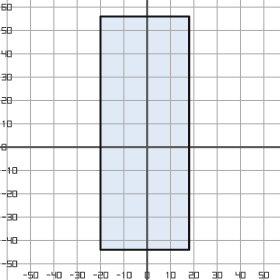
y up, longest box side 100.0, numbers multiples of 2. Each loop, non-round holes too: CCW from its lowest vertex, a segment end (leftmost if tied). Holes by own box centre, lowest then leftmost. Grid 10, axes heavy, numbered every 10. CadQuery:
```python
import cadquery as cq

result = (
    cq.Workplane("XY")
    .moveTo(-20.0, -44.0)
    .lineTo(18.0, -44.0)
    .lineTo(18.0, 56.0)
    .lineTo(-20.0, 56.0)
    .close()
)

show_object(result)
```